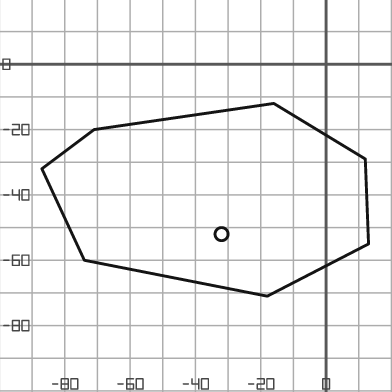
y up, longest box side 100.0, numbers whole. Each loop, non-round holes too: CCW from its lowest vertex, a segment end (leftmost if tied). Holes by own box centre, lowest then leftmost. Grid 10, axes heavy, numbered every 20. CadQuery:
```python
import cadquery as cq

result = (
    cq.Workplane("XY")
    .moveTo(-18.0, -71.0)
    .lineTo(13.0, -55.0)
    .lineTo(12.0, -29.0)
    .lineTo(-16.0, -12.0)
    .lineTo(-71.0, -20.0)
    .lineTo(-87.0, -32.0)
    .lineTo(-74.0, -60.0)
    .close()
    .moveTo(-32.0, -52.0)
    .circle(2.0)
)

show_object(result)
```